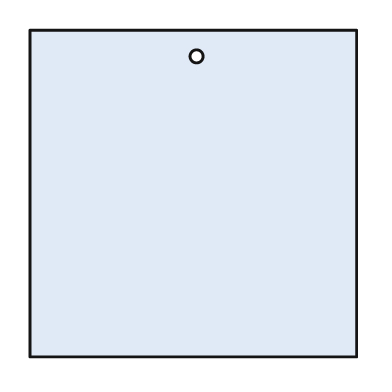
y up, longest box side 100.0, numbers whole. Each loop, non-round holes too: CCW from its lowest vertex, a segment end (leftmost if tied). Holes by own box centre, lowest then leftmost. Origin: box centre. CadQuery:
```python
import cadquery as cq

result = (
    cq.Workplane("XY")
    .moveTo(-50.0, -50.0)
    .lineTo(50.0, -50.0)
    .lineTo(50.0, 50.0)
    .lineTo(-50.0, 50.0)
    .close()
    .moveTo(1.0, 42.0)
    .circle(2.0)
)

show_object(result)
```